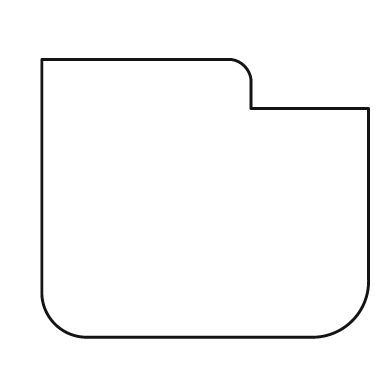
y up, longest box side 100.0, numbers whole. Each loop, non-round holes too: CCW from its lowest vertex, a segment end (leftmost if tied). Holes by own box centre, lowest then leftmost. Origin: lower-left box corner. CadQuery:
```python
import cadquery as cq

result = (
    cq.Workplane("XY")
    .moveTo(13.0, 0.0)
    .lineTo(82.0, 0.0)
    .threePointArc((95.0, 5.0), (100.0, 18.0))
    .lineTo(100.0, 70.0)
    .lineTo(64.0, 70.0)
    .lineTo(64.0, 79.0)
    .threePointArc((62.0, 83.0), (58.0, 85.0))
    .lineTo(0.0, 85.0)
    .lineTo(0.0, 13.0)
    .threePointArc((4.0, 4.0), (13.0, 0.0))
    .close()
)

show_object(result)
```